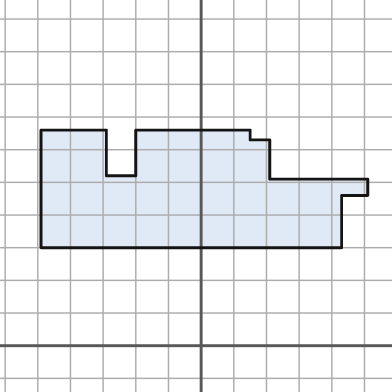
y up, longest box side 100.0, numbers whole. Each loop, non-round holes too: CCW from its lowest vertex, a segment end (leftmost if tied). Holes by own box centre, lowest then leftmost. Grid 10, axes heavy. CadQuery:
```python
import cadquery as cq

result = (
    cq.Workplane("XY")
    .moveTo(-49.0, 30.0)
    .lineTo(43.0, 30.0)
    .lineTo(43.0, 46.0)
    .lineTo(51.0, 46.0)
    .lineTo(51.0, 51.0)
    .lineTo(21.0, 51.0)
    .lineTo(21.0, 63.0)
    .lineTo(15.0, 63.0)
    .lineTo(15.0, 66.0)
    .lineTo(-20.0, 66.0)
    .lineTo(-20.0, 52.0)
    .lineTo(-29.0, 52.0)
    .lineTo(-29.0, 66.0)
    .lineTo(-49.0, 66.0)
    .close()
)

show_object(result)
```